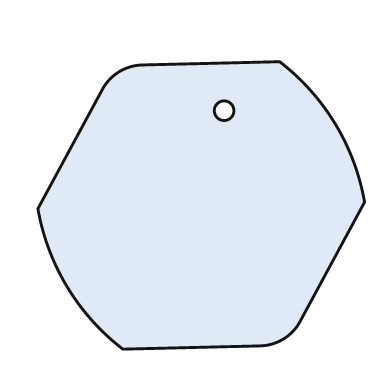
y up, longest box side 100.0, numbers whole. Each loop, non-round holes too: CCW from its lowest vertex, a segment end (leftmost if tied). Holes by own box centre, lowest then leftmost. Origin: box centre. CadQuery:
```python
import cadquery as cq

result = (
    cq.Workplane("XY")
    .moveTo(-24.0, -44.0)
    .lineTo(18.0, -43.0)
    .threePointArc((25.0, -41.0), (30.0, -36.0))
    .lineTo(50.0, 1.0)
    .threePointArc((41.0, 25.0), (24.0, 44.0))
    .lineTo(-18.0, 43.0)
    .threePointArc((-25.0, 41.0), (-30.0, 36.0))
    .lineTo(-50.0, -1.0)
    .threePointArc((-41.0, -25.0), (-24.0, -44.0))
    .close()
    .moveTo(7.0, 29.0)
    .circle(3.0)
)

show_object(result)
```